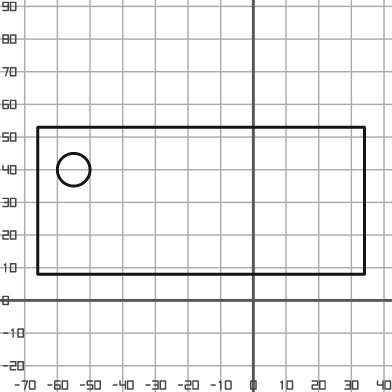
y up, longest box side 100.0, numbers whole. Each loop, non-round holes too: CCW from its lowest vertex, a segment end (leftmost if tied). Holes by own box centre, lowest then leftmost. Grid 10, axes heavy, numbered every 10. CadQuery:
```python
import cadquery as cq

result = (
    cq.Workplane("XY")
    .moveTo(-66.0, 8.0)
    .lineTo(34.0, 8.0)
    .lineTo(34.0, 53.0)
    .lineTo(-66.0, 53.0)
    .close()
    .moveTo(-55.0, 40.0)
    .circle(5.0)
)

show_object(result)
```